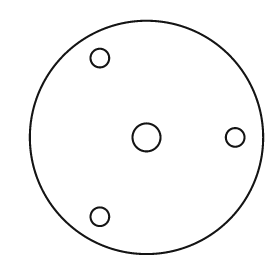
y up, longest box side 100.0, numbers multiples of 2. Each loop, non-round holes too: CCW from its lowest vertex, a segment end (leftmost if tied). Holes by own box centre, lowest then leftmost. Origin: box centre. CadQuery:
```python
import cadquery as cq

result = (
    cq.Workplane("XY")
    .moveTo(0.0, 0.0)
    .circle(50.0)
    .moveTo(-20.0, -34.0)
    .circle(4.0)
    .moveTo(0.0, 0.0)
    .circle(6.0)
    .moveTo(38.0, 0.0)
    .circle(4.0)
    .moveTo(-20.0, 34.0)
    .circle(4.0)
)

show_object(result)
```